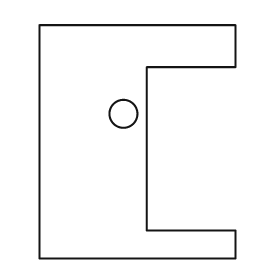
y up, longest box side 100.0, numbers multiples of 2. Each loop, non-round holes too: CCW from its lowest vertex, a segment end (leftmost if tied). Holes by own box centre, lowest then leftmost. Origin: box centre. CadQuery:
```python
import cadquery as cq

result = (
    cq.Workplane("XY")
    .moveTo(-42.0, -50.0)
    .lineTo(42.0, -50.0)
    .lineTo(42.0, -38.0)
    .lineTo(4.0, -38.0)
    .lineTo(4.0, 32.0)
    .lineTo(42.0, 32.0)
    .lineTo(42.0, 50.0)
    .lineTo(-42.0, 50.0)
    .close()
    .moveTo(-6.0, 12.0)
    .circle(6.0)
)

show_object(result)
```